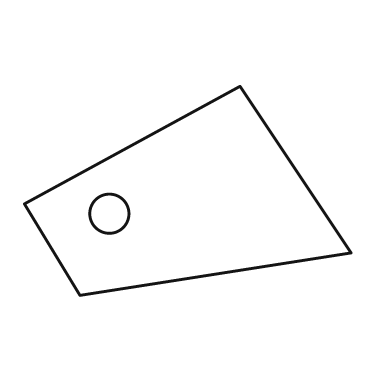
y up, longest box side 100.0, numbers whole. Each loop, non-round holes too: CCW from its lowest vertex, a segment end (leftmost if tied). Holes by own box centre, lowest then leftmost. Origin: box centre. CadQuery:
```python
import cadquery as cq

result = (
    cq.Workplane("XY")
    .moveTo(-33.0, -32.0)
    .lineTo(50.0, -19.0)
    .lineTo(16.0, 32.0)
    .lineTo(-50.0, -4.0)
    .close()
    .moveTo(-24.0, -7.0)
    .circle(6.0)
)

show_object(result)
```